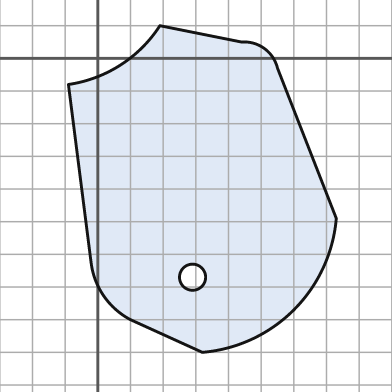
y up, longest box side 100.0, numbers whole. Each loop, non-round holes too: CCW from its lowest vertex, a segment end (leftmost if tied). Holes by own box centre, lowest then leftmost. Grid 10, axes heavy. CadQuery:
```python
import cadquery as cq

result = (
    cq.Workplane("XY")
    .moveTo(32.0, -90.0)
    .threePointArc((60.0, -77.0), (73.0, -49.0))
    .lineTo(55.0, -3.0)
    .threePointArc((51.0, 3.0), (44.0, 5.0))
    .lineTo(19.0, 10.0)
    .threePointArc((7.0, -2.0), (-9.0, -8.0))
    .lineTo(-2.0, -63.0)
    .threePointArc((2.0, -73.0), (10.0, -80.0))
    .close()
    .moveTo(29.0, -67.0)
    .circle(4.0)
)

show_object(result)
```